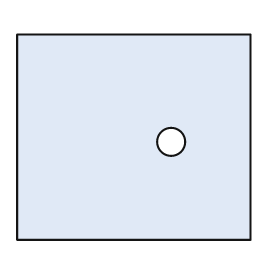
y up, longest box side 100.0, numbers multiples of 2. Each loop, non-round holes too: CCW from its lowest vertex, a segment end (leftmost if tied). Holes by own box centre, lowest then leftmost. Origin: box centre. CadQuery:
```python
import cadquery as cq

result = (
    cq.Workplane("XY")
    .moveTo(-50.0, -44.0)
    .lineTo(50.0, -44.0)
    .lineTo(50.0, 44.0)
    .lineTo(-50.0, 44.0)
    .close()
    .moveTo(16.0, -2.0)
    .circle(6.0)
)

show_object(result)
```